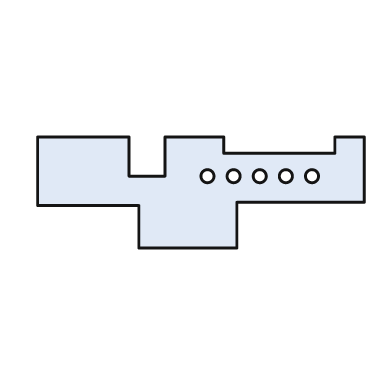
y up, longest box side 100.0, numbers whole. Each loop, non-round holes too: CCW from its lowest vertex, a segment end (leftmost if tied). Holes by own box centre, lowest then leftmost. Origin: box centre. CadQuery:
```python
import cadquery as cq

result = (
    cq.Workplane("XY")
    .moveTo(-19.0, -17.0)
    .lineTo(11.0, -17.0)
    .lineTo(11.0, -3.0)
    .lineTo(50.0, -3.0)
    .lineTo(50.0, 17.0)
    .lineTo(41.0, 17.0)
    .lineTo(41.0, 12.0)
    .lineTo(7.0, 12.0)
    .lineTo(7.0, 17.0)
    .lineTo(-11.0, 17.0)
    .lineTo(-11.0, 5.0)
    .lineTo(-22.0, 5.0)
    .lineTo(-22.0, 17.0)
    .lineTo(-50.0, 17.0)
    .lineTo(-50.0, -4.0)
    .lineTo(-19.0, -4.0)
    .close()
    .moveTo(2.0, 5.0)
    .circle(2.0)
    .moveTo(10.0, 5.0)
    .circle(2.0)
    .moveTo(18.0, 5.0)
    .circle(2.0)
    .moveTo(26.0, 5.0)
    .circle(2.0)
    .moveTo(34.0, 5.0)
    .circle(2.0)
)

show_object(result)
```